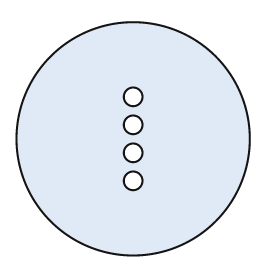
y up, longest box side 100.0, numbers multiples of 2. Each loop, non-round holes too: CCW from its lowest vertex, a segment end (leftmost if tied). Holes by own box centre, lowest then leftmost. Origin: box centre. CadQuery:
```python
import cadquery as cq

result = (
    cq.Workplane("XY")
    .moveTo(0.0, 0.0)
    .circle(50.0)
    .moveTo(0.0, -18.0)
    .circle(4.0)
    .moveTo(0.0, -6.0)
    .circle(4.0)
    .moveTo(0.0, 6.0)
    .circle(4.0)
    .moveTo(0.0, 18.0)
    .circle(4.0)
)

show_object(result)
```